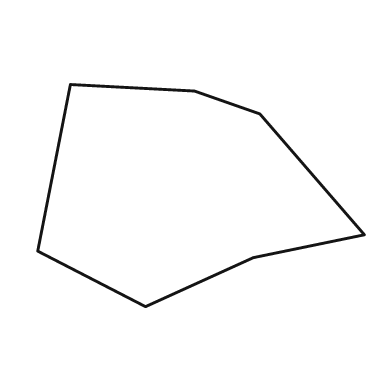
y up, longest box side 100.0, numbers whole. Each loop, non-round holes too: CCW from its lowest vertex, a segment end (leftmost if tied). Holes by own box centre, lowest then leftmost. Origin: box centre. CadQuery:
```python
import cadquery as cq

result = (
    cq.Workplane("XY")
    .moveTo(-17.0, -34.0)
    .lineTo(16.0, -19.0)
    .lineTo(50.0, -12.0)
    .lineTo(18.0, 25.0)
    .lineTo(-2.0, 32.0)
    .lineTo(-40.0, 34.0)
    .lineTo(-50.0, -17.0)
    .close()
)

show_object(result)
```